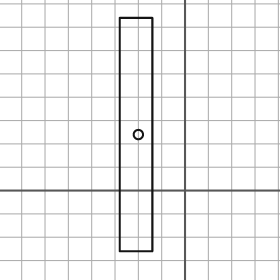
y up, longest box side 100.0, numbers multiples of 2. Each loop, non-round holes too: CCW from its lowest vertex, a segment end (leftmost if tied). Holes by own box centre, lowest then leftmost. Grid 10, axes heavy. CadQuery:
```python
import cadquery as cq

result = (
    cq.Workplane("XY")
    .moveTo(-28.0, -26.0)
    .lineTo(-14.0, -26.0)
    .lineTo(-14.0, 74.0)
    .lineTo(-28.0, 74.0)
    .close()
    .moveTo(-20.0, 24.0)
    .circle(2.0)
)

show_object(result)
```